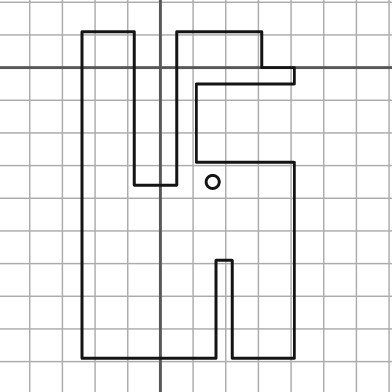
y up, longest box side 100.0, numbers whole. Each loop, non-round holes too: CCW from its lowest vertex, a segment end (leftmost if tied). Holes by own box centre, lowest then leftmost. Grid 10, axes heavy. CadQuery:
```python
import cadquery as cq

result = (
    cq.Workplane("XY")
    .moveTo(-24.0, -89.0)
    .lineTo(17.0, -89.0)
    .lineTo(17.0, -59.0)
    .lineTo(22.0, -59.0)
    .lineTo(22.0, -89.0)
    .lineTo(41.0, -89.0)
    .lineTo(41.0, -29.0)
    .lineTo(11.0, -29.0)
    .lineTo(11.0, -5.0)
    .lineTo(41.0, -5.0)
    .lineTo(41.0, 0.0)
    .lineTo(31.0, 0.0)
    .lineTo(31.0, 11.0)
    .lineTo(5.0, 11.0)
    .lineTo(5.0, -36.0)
    .lineTo(-8.0, -36.0)
    .lineTo(-8.0, 11.0)
    .lineTo(-24.0, 11.0)
    .close()
    .moveTo(16.0, -35.0)
    .circle(2.0)
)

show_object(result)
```